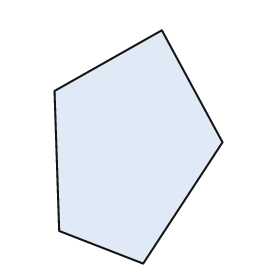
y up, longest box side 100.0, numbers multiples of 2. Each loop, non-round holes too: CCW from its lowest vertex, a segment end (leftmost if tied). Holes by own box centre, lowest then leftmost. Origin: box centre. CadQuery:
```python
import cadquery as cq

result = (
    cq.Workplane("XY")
    .moveTo(2.0, -50.0)
    .lineTo(36.0, 2.0)
    .lineTo(10.0, 50.0)
    .lineTo(-36.0, 24.0)
    .lineTo(-34.0, -36.0)
    .close()
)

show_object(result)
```